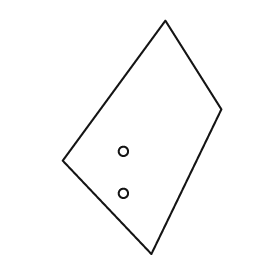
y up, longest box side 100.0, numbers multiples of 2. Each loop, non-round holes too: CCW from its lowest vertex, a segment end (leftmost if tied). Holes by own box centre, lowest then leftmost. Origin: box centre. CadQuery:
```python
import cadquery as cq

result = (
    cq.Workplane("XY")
    .moveTo(4.0, -50.0)
    .lineTo(34.0, 12.0)
    .lineTo(10.0, 50.0)
    .lineTo(-34.0, -10.0)
    .close()
    .moveTo(-8.0, -24.0)
    .circle(2.0)
    .moveTo(-8.0, -6.0)
    .circle(2.0)
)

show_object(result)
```